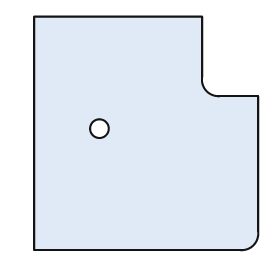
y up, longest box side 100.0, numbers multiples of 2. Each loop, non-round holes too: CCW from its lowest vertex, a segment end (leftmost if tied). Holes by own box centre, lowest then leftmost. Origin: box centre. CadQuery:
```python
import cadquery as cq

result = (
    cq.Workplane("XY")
    .moveTo(-48.0, -50.0)
    .lineTo(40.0, -50.0)
    .threePointArc((46.0, -48.0), (48.0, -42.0))
    .lineTo(48.0, 16.0)
    .lineTo(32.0, 16.0)
    .threePointArc((26.0, 18.0), (24.0, 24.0))
    .lineTo(24.0, 50.0)
    .lineTo(-48.0, 50.0)
    .close()
    .moveTo(-20.0, 2.0)
    .circle(4.0)
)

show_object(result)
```